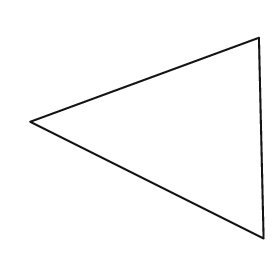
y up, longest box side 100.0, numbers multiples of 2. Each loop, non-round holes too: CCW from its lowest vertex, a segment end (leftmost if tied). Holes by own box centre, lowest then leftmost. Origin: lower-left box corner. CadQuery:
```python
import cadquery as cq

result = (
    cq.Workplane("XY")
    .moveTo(100.0, 0.0)
    .lineTo(98.0, 86.0)
    .lineTo(0.0, 50.0)
    .close()
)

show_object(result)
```